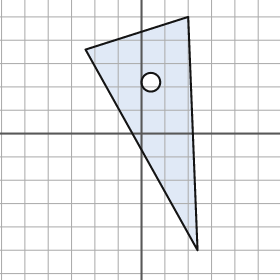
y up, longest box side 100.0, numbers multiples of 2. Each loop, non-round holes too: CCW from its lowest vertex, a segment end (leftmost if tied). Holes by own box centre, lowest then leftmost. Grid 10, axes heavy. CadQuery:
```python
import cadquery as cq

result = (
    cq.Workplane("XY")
    .moveTo(24.0, -50.0)
    .lineTo(20.0, 50.0)
    .lineTo(-24.0, 36.0)
    .close()
    .moveTo(4.0, 22.0)
    .circle(4.0)
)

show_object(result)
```